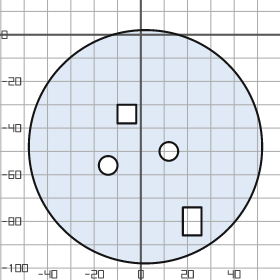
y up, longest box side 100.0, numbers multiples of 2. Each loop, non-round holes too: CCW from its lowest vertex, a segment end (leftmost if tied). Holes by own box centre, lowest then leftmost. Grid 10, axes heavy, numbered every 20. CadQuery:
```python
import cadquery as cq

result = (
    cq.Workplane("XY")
    .moveTo(2.0, -48.0)
    .circle(50.0)
    .moveTo(18.0, -86.0)
    .lineTo(26.0, -86.0)
    .lineTo(26.0, -74.0)
    .lineTo(18.0, -74.0)
    .close()
    .moveTo(-14.0, -56.0)
    .circle(4.0)
    .moveTo(12.0, -50.0)
    .circle(4.0)
    .moveTo(-10.0, -38.0)
    .lineTo(-2.0, -38.0)
    .lineTo(-2.0, -30.0)
    .lineTo(-10.0, -30.0)
    .close()
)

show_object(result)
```